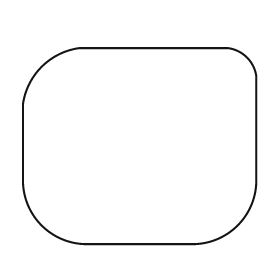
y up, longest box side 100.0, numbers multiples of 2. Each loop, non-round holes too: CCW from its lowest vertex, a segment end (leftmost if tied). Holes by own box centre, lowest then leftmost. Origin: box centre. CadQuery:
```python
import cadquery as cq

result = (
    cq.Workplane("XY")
    .moveTo(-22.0, -42.0)
    .lineTo(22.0, -42.0)
    .threePointArc((42.0, -34.0), (50.0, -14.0))
    .lineTo(50.0, 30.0)
    .threePointArc((46.0, 38.0), (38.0, 42.0))
    .lineTo(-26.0, 42.0)
    .threePointArc((-42.0, 34.0), (-50.0, 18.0))
    .lineTo(-50.0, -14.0)
    .threePointArc((-42.0, -34.0), (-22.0, -42.0))
    .close()
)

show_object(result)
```